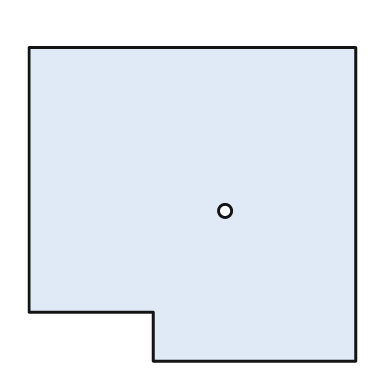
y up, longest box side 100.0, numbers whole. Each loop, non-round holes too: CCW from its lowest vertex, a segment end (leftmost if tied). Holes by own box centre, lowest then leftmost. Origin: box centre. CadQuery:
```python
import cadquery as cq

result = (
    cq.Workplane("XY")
    .moveTo(-12.0, -48.0)
    .lineTo(50.0, -48.0)
    .lineTo(50.0, 48.0)
    .lineTo(-50.0, 48.0)
    .lineTo(-50.0, -33.0)
    .lineTo(-12.0, -33.0)
    .close()
    .moveTo(10.0, -2.0)
    .circle(2.0)
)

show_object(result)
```